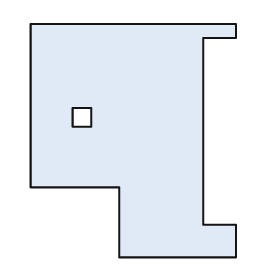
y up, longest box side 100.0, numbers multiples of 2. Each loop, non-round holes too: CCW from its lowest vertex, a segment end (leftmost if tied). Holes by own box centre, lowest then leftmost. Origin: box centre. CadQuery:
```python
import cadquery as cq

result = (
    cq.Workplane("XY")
    .moveTo(-6.0, -50.0)
    .lineTo(44.0, -50.0)
    .lineTo(44.0, -36.0)
    .lineTo(30.0, -36.0)
    .lineTo(30.0, 44.0)
    .lineTo(44.0, 44.0)
    .lineTo(44.0, 50.0)
    .lineTo(-44.0, 50.0)
    .lineTo(-44.0, -20.0)
    .lineTo(-6.0, -20.0)
    .close()
    .moveTo(-26.0, 6.0)
    .lineTo(-18.0, 6.0)
    .lineTo(-18.0, 14.0)
    .lineTo(-26.0, 14.0)
    .close()
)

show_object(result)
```